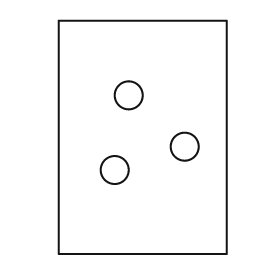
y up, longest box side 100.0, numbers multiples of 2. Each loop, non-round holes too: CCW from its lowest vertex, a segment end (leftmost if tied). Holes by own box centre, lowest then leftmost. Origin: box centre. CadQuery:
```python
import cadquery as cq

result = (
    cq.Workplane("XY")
    .moveTo(-36.0, -50.0)
    .lineTo(36.0, -50.0)
    .lineTo(36.0, 50.0)
    .lineTo(-36.0, 50.0)
    .close()
    .moveTo(-12.0, -14.0)
    .circle(6.0)
    .moveTo(18.0, -4.0)
    .circle(6.0)
    .moveTo(-6.0, 18.0)
    .circle(6.0)
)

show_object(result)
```